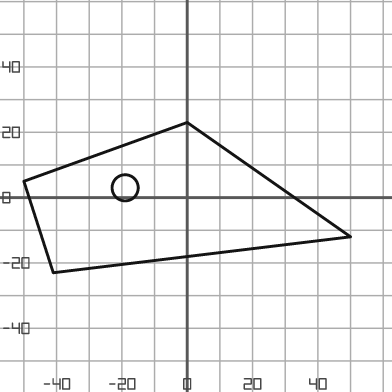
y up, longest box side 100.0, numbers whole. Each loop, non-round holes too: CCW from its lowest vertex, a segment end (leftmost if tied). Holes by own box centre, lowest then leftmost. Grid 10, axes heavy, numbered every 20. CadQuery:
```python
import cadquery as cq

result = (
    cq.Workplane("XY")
    .moveTo(-41.0, -23.0)
    .lineTo(50.0, -12.0)
    .lineTo(0.0, 23.0)
    .lineTo(-50.0, 5.0)
    .close()
    .moveTo(-19.0, 3.0)
    .circle(4.0)
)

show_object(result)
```